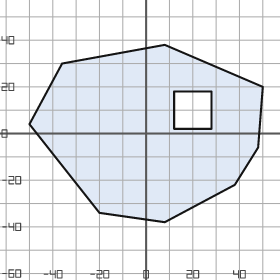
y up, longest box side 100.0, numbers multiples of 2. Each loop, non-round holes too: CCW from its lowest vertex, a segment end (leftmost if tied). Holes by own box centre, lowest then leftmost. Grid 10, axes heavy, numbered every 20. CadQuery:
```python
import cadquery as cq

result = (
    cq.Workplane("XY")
    .moveTo(8.0, -38.0)
    .lineTo(38.0, -22.0)
    .lineTo(48.0, -6.0)
    .lineTo(50.0, 20.0)
    .lineTo(8.0, 38.0)
    .lineTo(-36.0, 30.0)
    .lineTo(-50.0, 4.0)
    .lineTo(-20.0, -34.0)
    .close()
    .moveTo(12.0, 2.0)
    .lineTo(28.0, 2.0)
    .lineTo(28.0, 18.0)
    .lineTo(12.0, 18.0)
    .close()
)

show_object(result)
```